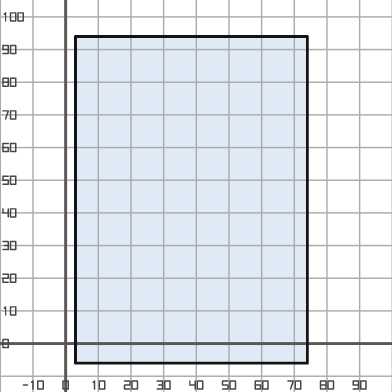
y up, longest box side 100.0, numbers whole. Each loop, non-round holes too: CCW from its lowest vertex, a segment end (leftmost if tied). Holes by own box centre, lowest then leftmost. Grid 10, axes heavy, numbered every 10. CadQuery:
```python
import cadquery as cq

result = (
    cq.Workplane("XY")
    .moveTo(3.0, -6.0)
    .lineTo(74.0, -6.0)
    .lineTo(74.0, 94.0)
    .lineTo(3.0, 94.0)
    .close()
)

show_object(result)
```